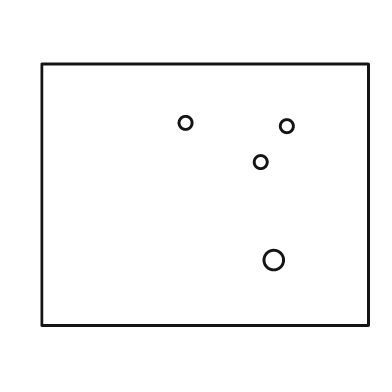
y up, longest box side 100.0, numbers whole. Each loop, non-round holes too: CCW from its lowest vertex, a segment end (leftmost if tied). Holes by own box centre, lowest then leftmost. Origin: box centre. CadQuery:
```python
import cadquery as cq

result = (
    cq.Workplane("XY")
    .moveTo(-50.0, -40.0)
    .lineTo(50.0, -40.0)
    .lineTo(50.0, 40.0)
    .lineTo(-50.0, 40.0)
    .close()
    .moveTo(21.0, -20.0)
    .circle(3.0)
    .moveTo(17.0, 10.0)
    .circle(2.0)
    .moveTo(25.0, 21.0)
    .circle(2.0)
    .moveTo(-6.0, 22.0)
    .circle(2.0)
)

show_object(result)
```